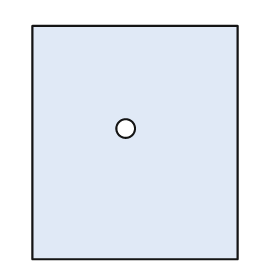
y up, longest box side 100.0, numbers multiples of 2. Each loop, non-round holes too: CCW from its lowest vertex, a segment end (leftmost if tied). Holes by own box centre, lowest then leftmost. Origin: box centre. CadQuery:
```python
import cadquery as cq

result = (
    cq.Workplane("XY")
    .moveTo(-44.0, -50.0)
    .lineTo(44.0, -50.0)
    .lineTo(44.0, 50.0)
    .lineTo(-44.0, 50.0)
    .close()
    .moveTo(-4.0, 6.0)
    .circle(4.0)
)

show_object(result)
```